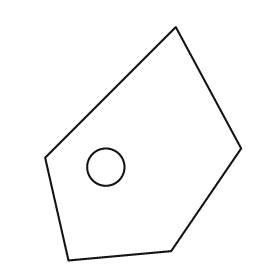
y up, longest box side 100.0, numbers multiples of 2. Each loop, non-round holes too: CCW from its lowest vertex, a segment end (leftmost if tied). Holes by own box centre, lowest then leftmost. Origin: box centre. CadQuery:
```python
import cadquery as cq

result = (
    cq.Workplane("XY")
    .moveTo(-32.0, -50.0)
    .lineTo(12.0, -46.0)
    .lineTo(42.0, -2.0)
    .lineTo(14.0, 50.0)
    .lineTo(-42.0, -6.0)
    .close()
    .moveTo(-16.0, -10.0)
    .circle(8.0)
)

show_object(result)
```